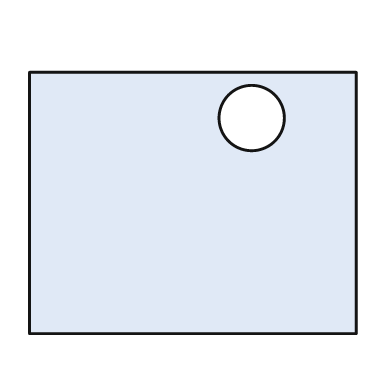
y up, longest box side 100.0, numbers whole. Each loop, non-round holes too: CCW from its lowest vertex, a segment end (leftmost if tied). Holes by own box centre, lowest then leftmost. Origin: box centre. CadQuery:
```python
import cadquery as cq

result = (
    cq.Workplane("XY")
    .moveTo(-50.0, -40.0)
    .lineTo(50.0, -40.0)
    .lineTo(50.0, 40.0)
    .lineTo(-50.0, 40.0)
    .close()
    .moveTo(18.0, 26.0)
    .circle(10.0)
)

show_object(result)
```